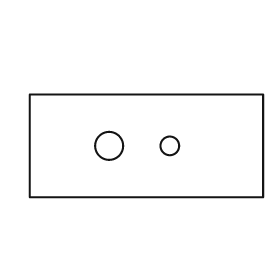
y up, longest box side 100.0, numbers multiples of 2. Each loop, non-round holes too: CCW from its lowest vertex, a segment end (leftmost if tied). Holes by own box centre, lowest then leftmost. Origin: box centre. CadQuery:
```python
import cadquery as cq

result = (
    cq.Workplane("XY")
    .moveTo(-50.0, -22.0)
    .lineTo(50.0, -22.0)
    .lineTo(50.0, 22.0)
    .lineTo(-50.0, 22.0)
    .close()
    .moveTo(-16.0, 0.0)
    .circle(6.0)
    .moveTo(10.0, 0.0)
    .circle(4.0)
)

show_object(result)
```